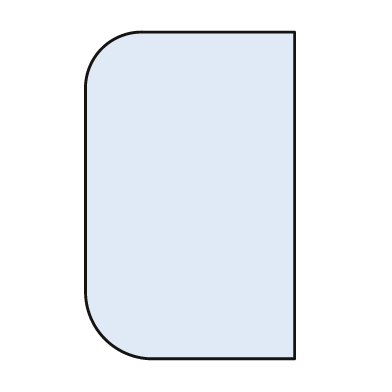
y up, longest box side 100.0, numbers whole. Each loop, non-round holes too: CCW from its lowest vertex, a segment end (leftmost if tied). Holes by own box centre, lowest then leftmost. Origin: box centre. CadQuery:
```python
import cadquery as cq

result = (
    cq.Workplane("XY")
    .moveTo(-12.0, -50.0)
    .lineTo(32.0, -50.0)
    .lineTo(32.0, 50.0)
    .lineTo(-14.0, 50.0)
    .threePointArc((-27.0, 45.0), (-32.0, 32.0))
    .lineTo(-32.0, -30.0)
    .threePointArc((-26.0, -44.0), (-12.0, -50.0))
    .close()
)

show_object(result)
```